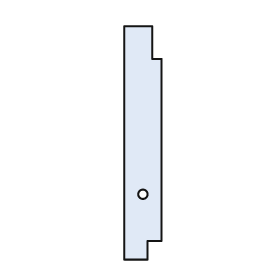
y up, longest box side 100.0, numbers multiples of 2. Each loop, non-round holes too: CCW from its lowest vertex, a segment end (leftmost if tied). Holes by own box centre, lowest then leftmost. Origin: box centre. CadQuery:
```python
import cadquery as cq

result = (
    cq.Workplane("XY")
    .moveTo(-8.0, -50.0)
    .lineTo(2.0, -50.0)
    .lineTo(2.0, -42.0)
    .lineTo(8.0, -42.0)
    .lineTo(8.0, 36.0)
    .lineTo(4.0, 36.0)
    .lineTo(4.0, 50.0)
    .lineTo(-8.0, 50.0)
    .close()
    .moveTo(0.0, -22.0)
    .circle(2.0)
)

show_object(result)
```